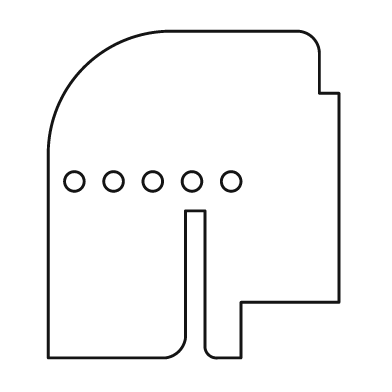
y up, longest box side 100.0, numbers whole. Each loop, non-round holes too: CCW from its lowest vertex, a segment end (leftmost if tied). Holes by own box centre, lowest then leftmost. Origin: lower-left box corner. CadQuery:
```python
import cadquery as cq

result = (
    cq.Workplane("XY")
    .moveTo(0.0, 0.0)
    .lineTo(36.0, 0.0)
    .threePointArc((40.0, 2.0), (42.0, 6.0))
    .lineTo(42.0, 45.0)
    .lineTo(48.0, 45.0)
    .lineTo(48.0, 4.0)
    .threePointArc((49.0, 1.0), (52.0, 0.0))
    .lineTo(59.0, 0.0)
    .lineTo(59.0, 17.0)
    .lineTo(89.0, 17.0)
    .lineTo(89.0, 81.0)
    .lineTo(83.0, 81.0)
    .lineTo(83.0, 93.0)
    .threePointArc((81.0, 98.0), (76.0, 100.0))
    .lineTo(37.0, 100.0)
    .threePointArc((11.0, 89.0), (0.0, 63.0))
    .close()
    .moveTo(8.0, 54.0)
    .circle(3.0)
    .moveTo(20.0, 54.0)
    .circle(3.0)
    .moveTo(32.0, 54.0)
    .circle(3.0)
    .moveTo(44.0, 54.0)
    .circle(3.0)
    .moveTo(56.0, 54.0)
    .circle(3.0)
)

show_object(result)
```